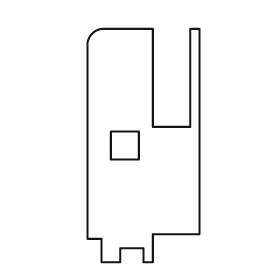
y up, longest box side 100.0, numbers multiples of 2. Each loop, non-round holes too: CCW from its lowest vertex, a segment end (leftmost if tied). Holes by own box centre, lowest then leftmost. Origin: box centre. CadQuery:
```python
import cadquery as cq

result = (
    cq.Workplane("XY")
    .moveTo(-18.0, -50.0)
    .lineTo(-10.0, -50.0)
    .lineTo(-10.0, -44.0)
    .lineTo(0.0, -44.0)
    .lineTo(0.0, -50.0)
    .lineTo(4.0, -50.0)
    .lineTo(4.0, -38.0)
    .lineTo(24.0, -38.0)
    .lineTo(24.0, 50.0)
    .lineTo(20.0, 50.0)
    .lineTo(20.0, 8.0)
    .lineTo(4.0, 8.0)
    .lineTo(4.0, 50.0)
    .lineTo(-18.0, 50.0)
    .threePointArc((-22.0, 48.0), (-24.0, 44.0))
    .lineTo(-24.0, -40.0)
    .lineTo(-18.0, -40.0)
    .close()
    .moveTo(-14.0, -6.0)
    .lineTo(-2.0, -6.0)
    .lineTo(-2.0, 6.0)
    .lineTo(-14.0, 6.0)
    .close()
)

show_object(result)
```